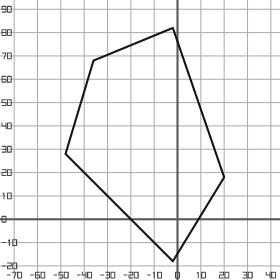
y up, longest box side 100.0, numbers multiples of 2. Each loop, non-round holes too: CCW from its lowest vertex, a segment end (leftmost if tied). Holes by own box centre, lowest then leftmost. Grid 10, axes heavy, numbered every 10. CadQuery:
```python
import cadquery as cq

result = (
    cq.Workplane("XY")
    .moveTo(-2.0, -18.0)
    .lineTo(20.0, 18.0)
    .lineTo(-2.0, 82.0)
    .lineTo(-36.0, 68.0)
    .lineTo(-48.0, 28.0)
    .close()
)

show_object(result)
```